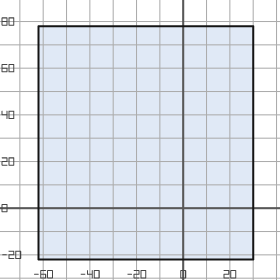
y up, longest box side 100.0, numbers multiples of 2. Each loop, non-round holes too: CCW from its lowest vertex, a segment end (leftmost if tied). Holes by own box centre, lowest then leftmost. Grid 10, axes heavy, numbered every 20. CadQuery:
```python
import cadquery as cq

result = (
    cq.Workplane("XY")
    .moveTo(-62.0, -22.0)
    .lineTo(30.0, -22.0)
    .lineTo(30.0, 78.0)
    .lineTo(-62.0, 78.0)
    .close()
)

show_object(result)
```